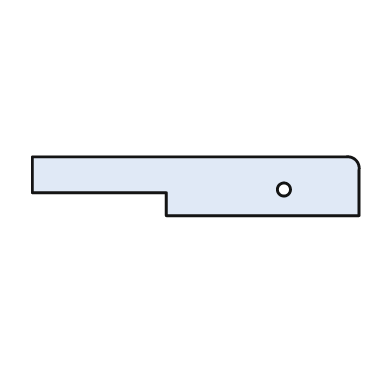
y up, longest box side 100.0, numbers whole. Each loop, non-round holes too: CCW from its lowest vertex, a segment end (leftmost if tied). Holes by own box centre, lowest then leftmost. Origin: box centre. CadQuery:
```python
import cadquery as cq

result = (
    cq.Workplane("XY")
    .moveTo(-9.0, -9.0)
    .lineTo(50.0, -9.0)
    .lineTo(50.0, 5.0)
    .threePointArc((49.0, 8.0), (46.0, 9.0))
    .lineTo(-50.0, 9.0)
    .lineTo(-50.0, -2.0)
    .lineTo(-9.0, -2.0)
    .close()
    .moveTo(27.0, -1.0)
    .circle(2.0)
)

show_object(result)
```